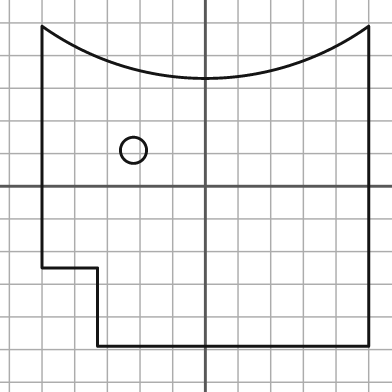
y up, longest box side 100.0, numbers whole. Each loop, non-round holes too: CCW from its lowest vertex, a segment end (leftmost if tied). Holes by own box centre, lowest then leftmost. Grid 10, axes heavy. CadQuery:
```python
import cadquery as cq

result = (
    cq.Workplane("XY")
    .moveTo(-33.0, -49.0)
    .lineTo(50.0, -49.0)
    .lineTo(50.0, 49.0)
    .threePointArc((0.0, 33.0), (-50.0, 49.0))
    .lineTo(-50.0, -25.0)
    .lineTo(-33.0, -25.0)
    .close()
    .moveTo(-22.0, 11.0)
    .circle(4.0)
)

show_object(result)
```